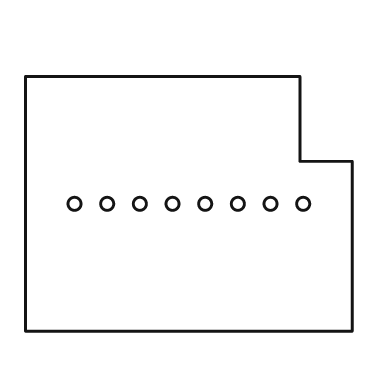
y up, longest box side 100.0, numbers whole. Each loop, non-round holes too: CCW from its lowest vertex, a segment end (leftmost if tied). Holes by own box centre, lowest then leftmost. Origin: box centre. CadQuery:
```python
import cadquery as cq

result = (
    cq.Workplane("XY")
    .moveTo(-50.0, -39.0)
    .lineTo(50.0, -39.0)
    .lineTo(50.0, 13.0)
    .lineTo(34.0, 13.0)
    .lineTo(34.0, 39.0)
    .lineTo(-50.0, 39.0)
    .close()
    .moveTo(-35.0, 0.0)
    .circle(2.0)
    .moveTo(-25.0, 0.0)
    .circle(2.0)
    .moveTo(-15.0, 0.0)
    .circle(2.0)
    .moveTo(-5.0, 0.0)
    .circle(2.0)
    .moveTo(5.0, 0.0)
    .circle(2.0)
    .moveTo(15.0, 0.0)
    .circle(2.0)
    .moveTo(25.0, 0.0)
    .circle(2.0)
    .moveTo(35.0, 0.0)
    .circle(2.0)
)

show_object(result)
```